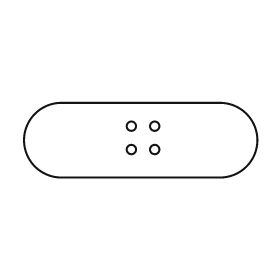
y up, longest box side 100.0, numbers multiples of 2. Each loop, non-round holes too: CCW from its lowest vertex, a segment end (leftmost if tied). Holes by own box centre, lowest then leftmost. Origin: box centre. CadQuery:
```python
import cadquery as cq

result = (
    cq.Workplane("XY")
    .moveTo(-34.0, -16.0)
    .lineTo(34.0, -16.0)
    .threePointArc((50.0, 0.0), (34.0, 16.0))
    .lineTo(-34.0, 16.0)
    .threePointArc((-50.0, 0.0), (-34.0, -16.0))
    .close()
    .moveTo(-4.0, -4.0)
    .circle(2.0)
    .moveTo(6.0, -4.0)
    .circle(2.0)
    .moveTo(-4.0, 6.0)
    .circle(2.0)
    .moveTo(6.0, 6.0)
    .circle(2.0)
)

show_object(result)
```